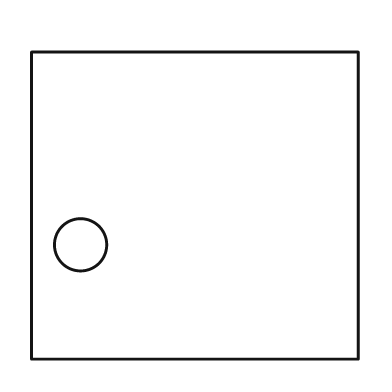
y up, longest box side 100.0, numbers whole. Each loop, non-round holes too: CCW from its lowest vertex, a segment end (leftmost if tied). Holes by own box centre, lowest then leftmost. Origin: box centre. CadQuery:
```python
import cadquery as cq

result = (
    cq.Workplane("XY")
    .moveTo(-50.0, -47.0)
    .lineTo(50.0, -47.0)
    .lineTo(50.0, 47.0)
    .lineTo(-50.0, 47.0)
    .close()
    .moveTo(-35.0, -12.0)
    .circle(8.0)
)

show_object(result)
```